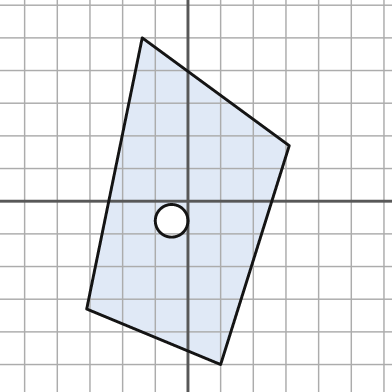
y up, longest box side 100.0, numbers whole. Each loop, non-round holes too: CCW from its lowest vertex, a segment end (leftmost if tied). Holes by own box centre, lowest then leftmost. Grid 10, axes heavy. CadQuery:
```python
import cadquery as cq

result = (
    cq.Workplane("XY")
    .moveTo(10.0, -50.0)
    .lineTo(31.0, 17.0)
    .lineTo(-14.0, 50.0)
    .lineTo(-31.0, -33.0)
    .close()
    .moveTo(-5.0, -6.0)
    .circle(5.0)
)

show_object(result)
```